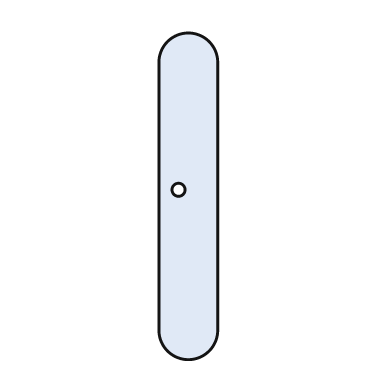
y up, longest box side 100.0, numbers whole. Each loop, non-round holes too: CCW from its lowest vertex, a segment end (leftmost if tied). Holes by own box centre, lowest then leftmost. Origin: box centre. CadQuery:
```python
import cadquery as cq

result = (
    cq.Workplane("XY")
    .moveTo(-9.0, -41.0)
    .threePointArc((0.0, -50.0), (9.0, -41.0))
    .lineTo(9.0, 41.0)
    .threePointArc((0.0, 50.0), (-9.0, 41.0))
    .close()
    .moveTo(-3.0, 2.0)
    .circle(2.0)
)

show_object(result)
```